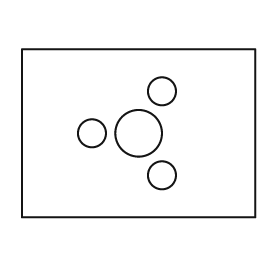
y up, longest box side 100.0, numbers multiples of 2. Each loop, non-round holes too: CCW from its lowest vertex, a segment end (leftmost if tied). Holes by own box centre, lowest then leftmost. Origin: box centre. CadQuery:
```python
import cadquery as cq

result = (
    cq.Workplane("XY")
    .moveTo(-50.0, -36.0)
    .lineTo(50.0, -36.0)
    .lineTo(50.0, 36.0)
    .lineTo(-50.0, 36.0)
    .close()
    .moveTo(10.0, -18.0)
    .circle(6.0)
    .moveTo(-20.0, 0.0)
    .circle(6.0)
    .moveTo(0.0, 0.0)
    .circle(10.0)
    .moveTo(10.0, 18.0)
    .circle(6.0)
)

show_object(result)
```